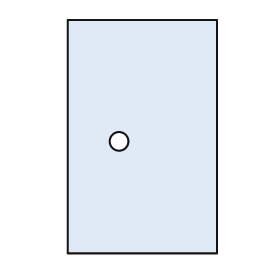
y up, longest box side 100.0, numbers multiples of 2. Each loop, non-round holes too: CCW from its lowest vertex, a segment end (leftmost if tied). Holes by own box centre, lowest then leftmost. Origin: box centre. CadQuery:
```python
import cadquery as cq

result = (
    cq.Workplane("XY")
    .moveTo(-32.0, -50.0)
    .lineTo(32.0, -50.0)
    .lineTo(32.0, 50.0)
    .lineTo(-32.0, 50.0)
    .close()
    .moveTo(-10.0, -2.0)
    .circle(4.0)
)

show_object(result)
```